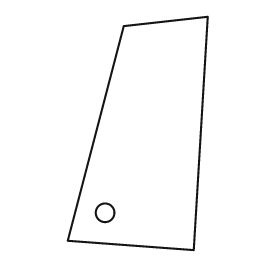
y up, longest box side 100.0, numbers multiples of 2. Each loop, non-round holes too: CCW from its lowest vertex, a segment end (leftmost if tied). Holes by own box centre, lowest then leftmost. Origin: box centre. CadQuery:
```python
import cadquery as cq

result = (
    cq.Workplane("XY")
    .moveTo(24.0, -50.0)
    .lineTo(30.0, 50.0)
    .lineTo(-6.0, 46.0)
    .lineTo(-30.0, -46.0)
    .close()
    .moveTo(-14.0, -34.0)
    .circle(4.0)
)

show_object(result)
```